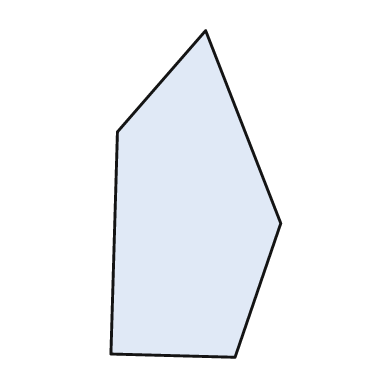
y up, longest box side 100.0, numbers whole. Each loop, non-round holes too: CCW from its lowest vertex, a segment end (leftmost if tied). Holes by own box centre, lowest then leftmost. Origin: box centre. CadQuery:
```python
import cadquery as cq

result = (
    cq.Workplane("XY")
    .moveTo(12.0, -50.0)
    .lineTo(26.0, -9.0)
    .lineTo(3.0, 50.0)
    .lineTo(-24.0, 19.0)
    .lineTo(-26.0, -49.0)
    .close()
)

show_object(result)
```